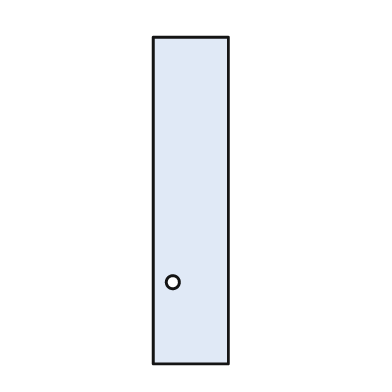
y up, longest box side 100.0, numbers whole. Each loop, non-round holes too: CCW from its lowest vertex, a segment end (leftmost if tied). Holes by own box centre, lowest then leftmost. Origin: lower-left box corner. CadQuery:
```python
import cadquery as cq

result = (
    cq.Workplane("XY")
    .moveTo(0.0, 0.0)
    .lineTo(23.0, 0.0)
    .lineTo(23.0, 100.0)
    .lineTo(0.0, 100.0)
    .close()
    .moveTo(6.0, 25.0)
    .circle(2.0)
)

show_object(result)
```